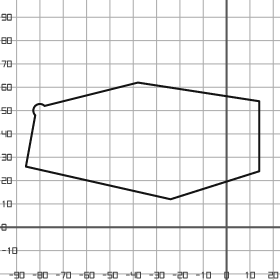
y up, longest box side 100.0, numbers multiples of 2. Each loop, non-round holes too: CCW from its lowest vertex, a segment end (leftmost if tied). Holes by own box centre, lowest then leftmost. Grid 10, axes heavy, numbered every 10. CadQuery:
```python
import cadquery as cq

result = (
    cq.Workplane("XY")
    .moveTo(-24.0, 12.0)
    .lineTo(14.0, 24.0)
    .lineTo(14.0, 54.0)
    .lineTo(-38.0, 62.0)
    .lineTo(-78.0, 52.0)
    .threePointArc((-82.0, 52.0), (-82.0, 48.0))
    .lineTo(-86.0, 26.0)
    .close()
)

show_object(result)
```